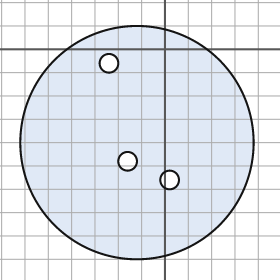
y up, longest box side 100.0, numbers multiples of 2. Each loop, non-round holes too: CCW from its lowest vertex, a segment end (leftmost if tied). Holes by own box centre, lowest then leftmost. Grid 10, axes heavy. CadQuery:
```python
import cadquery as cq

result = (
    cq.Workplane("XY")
    .moveTo(-12.0, -40.0)
    .circle(50.0)
    .moveTo(2.0, -56.0)
    .circle(4.0)
    .moveTo(-16.0, -48.0)
    .circle(4.0)
    .moveTo(-24.0, -6.0)
    .circle(4.0)
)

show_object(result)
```